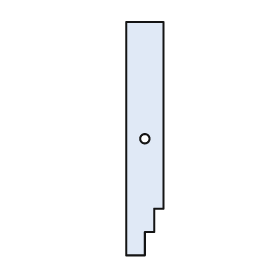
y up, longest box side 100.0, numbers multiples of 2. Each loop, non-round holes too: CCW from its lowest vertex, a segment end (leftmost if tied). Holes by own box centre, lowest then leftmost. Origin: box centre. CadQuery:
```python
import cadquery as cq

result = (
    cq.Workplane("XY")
    .moveTo(-8.0, -50.0)
    .lineTo(0.0, -50.0)
    .lineTo(0.0, -40.0)
    .lineTo(4.0, -40.0)
    .lineTo(4.0, -30.0)
    .lineTo(8.0, -30.0)
    .lineTo(8.0, 50.0)
    .lineTo(-8.0, 50.0)
    .close()
    .moveTo(0.0, 0.0)
    .circle(2.0)
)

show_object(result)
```